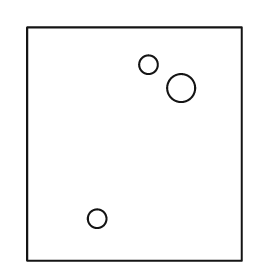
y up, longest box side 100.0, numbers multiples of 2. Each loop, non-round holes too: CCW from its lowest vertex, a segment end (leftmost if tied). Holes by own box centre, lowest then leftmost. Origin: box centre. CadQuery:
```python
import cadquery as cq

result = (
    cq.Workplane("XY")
    .moveTo(-46.0, -50.0)
    .lineTo(46.0, -50.0)
    .lineTo(46.0, 50.0)
    .lineTo(-46.0, 50.0)
    .close()
    .moveTo(-16.0, -32.0)
    .circle(4.0)
    .moveTo(20.0, 24.0)
    .circle(6.0)
    .moveTo(6.0, 34.0)
    .circle(4.0)
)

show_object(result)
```